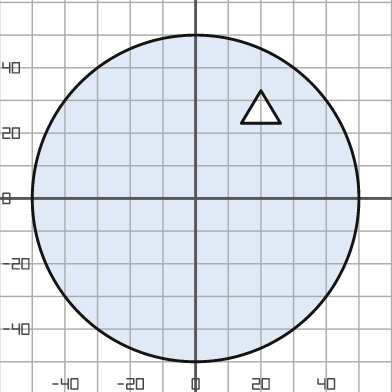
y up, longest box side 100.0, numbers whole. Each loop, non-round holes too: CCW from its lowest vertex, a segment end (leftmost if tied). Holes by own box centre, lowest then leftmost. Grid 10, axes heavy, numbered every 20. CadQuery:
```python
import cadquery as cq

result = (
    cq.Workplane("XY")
    .moveTo(0.0, 0.0)
    .circle(50.0)
    .moveTo(14.0, 23.0)
    .lineTo(26.0, 23.0)
    .lineTo(20.0, 33.0)
    .close()
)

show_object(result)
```